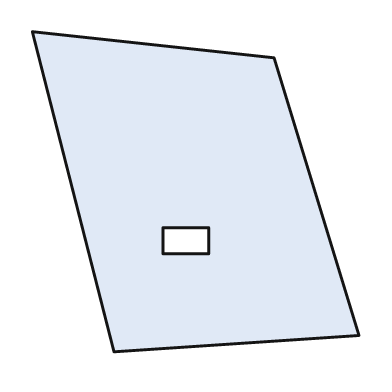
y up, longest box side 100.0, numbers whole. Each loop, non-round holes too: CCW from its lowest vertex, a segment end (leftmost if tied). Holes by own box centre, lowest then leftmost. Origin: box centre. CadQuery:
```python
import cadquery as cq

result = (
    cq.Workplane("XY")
    .moveTo(-25.0, -49.0)
    .lineTo(50.0, -44.0)
    .lineTo(24.0, 41.0)
    .lineTo(-50.0, 49.0)
    .close()
    .moveTo(-10.0, -19.0)
    .lineTo(4.0, -19.0)
    .lineTo(4.0, -11.0)
    .lineTo(-10.0, -11.0)
    .close()
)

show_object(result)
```